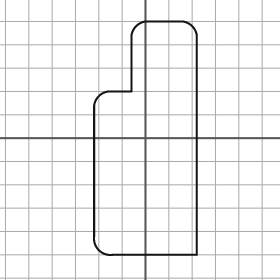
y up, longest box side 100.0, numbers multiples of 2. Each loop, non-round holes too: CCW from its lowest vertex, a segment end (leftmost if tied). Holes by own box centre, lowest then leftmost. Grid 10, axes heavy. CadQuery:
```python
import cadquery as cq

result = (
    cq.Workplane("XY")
    .moveTo(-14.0, -50.0)
    .lineTo(22.0, -50.0)
    .lineTo(22.0, 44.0)
    .threePointArc((20.0, 48.0), (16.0, 50.0))
    .lineTo(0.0, 50.0)
    .threePointArc((-4.0, 48.0), (-6.0, 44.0))
    .lineTo(-6.0, 20.0)
    .lineTo(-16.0, 20.0)
    .threePointArc((-20.0, 18.0), (-22.0, 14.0))
    .lineTo(-22.0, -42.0)
    .threePointArc((-20.0, -48.0), (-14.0, -50.0))
    .close()
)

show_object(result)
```